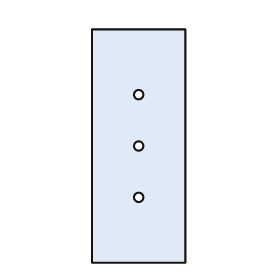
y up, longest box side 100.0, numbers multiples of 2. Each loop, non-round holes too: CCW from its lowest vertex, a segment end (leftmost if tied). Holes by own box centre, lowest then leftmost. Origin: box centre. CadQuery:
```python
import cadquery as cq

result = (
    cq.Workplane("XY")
    .moveTo(-20.0, -50.0)
    .lineTo(20.0, -50.0)
    .lineTo(20.0, 50.0)
    .lineTo(-20.0, 50.0)
    .close()
    .moveTo(0.0, -22.0)
    .circle(2.0)
    .moveTo(0.0, 0.0)
    .circle(2.0)
    .moveTo(0.0, 22.0)
    .circle(2.0)
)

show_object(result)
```